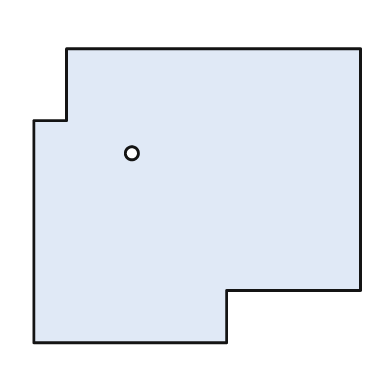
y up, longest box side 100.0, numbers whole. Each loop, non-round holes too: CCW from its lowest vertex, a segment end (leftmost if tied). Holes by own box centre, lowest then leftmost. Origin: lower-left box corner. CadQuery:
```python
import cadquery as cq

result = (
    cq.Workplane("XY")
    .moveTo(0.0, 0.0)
    .lineTo(59.0, 0.0)
    .lineTo(59.0, 16.0)
    .lineTo(100.0, 16.0)
    .lineTo(100.0, 90.0)
    .lineTo(10.0, 90.0)
    .lineTo(10.0, 68.0)
    .lineTo(0.0, 68.0)
    .close()
    .moveTo(30.0, 58.0)
    .circle(2.0)
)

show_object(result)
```